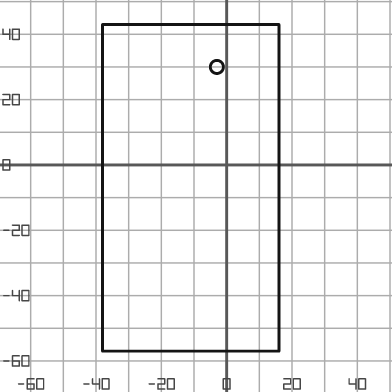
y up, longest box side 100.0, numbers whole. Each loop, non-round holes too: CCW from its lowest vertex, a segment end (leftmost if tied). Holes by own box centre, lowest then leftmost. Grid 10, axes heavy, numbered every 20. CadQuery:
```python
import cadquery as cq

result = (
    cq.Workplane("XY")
    .moveTo(-38.0, -57.0)
    .lineTo(16.0, -57.0)
    .lineTo(16.0, 43.0)
    .lineTo(-38.0, 43.0)
    .close()
    .moveTo(-3.0, 30.0)
    .circle(2.0)
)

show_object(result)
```